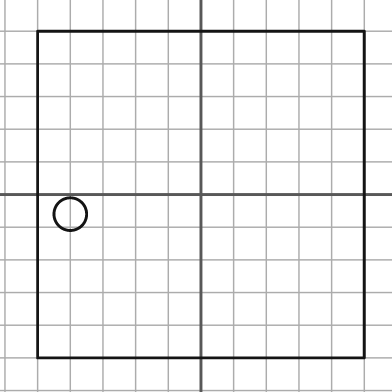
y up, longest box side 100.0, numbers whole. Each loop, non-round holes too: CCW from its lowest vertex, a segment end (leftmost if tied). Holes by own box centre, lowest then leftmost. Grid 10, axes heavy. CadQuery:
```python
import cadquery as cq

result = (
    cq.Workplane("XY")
    .moveTo(-50.0, -50.0)
    .lineTo(50.0, -50.0)
    .lineTo(50.0, 50.0)
    .lineTo(-50.0, 50.0)
    .close()
    .moveTo(-40.0, -6.0)
    .circle(5.0)
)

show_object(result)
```